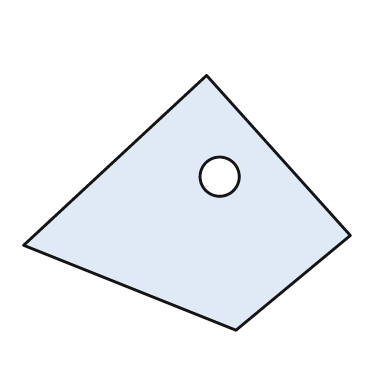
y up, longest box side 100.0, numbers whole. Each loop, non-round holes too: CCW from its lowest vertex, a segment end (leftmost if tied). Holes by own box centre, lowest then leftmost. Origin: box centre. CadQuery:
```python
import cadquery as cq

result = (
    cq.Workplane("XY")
    .moveTo(15.0, -39.0)
    .lineTo(50.0, -10.0)
    .lineTo(6.0, 39.0)
    .lineTo(-50.0, -13.0)
    .close()
    .moveTo(10.0, 8.0)
    .circle(6.0)
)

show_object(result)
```